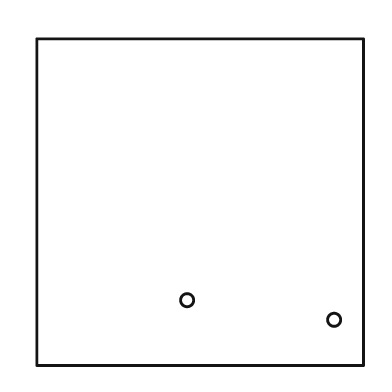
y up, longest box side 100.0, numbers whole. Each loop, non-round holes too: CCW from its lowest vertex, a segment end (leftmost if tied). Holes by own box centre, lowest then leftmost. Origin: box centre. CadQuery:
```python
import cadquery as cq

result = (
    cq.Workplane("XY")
    .moveTo(-50.0, -50.0)
    .lineTo(50.0, -50.0)
    .lineTo(50.0, 50.0)
    .lineTo(-50.0, 50.0)
    .close()
    .moveTo(41.0, -36.0)
    .circle(2.0)
    .moveTo(-4.0, -30.0)
    .circle(2.0)
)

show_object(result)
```